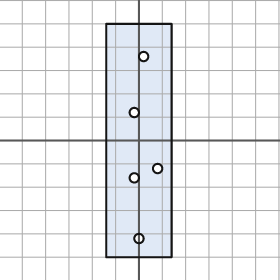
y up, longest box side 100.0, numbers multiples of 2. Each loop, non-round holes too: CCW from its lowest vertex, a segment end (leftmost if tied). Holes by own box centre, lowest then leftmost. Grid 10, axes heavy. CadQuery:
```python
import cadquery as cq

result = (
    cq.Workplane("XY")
    .moveTo(-14.0, -50.0)
    .lineTo(14.0, -50.0)
    .lineTo(14.0, 50.0)
    .lineTo(-14.0, 50.0)
    .close()
    .moveTo(0.0, -42.0)
    .circle(2.0)
    .moveTo(-2.0, -16.0)
    .circle(2.0)
    .moveTo(8.0, -12.0)
    .circle(2.0)
    .moveTo(-2.0, 12.0)
    .circle(2.0)
    .moveTo(2.0, 36.0)
    .circle(2.0)
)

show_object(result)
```